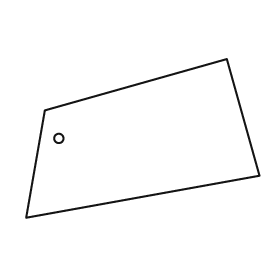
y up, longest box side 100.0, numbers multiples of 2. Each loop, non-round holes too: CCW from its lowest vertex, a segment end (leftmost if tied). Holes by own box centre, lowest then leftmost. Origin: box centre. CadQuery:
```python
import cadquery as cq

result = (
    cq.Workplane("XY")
    .moveTo(-50.0, -34.0)
    .lineTo(50.0, -16.0)
    .lineTo(36.0, 34.0)
    .lineTo(-42.0, 12.0)
    .close()
    .moveTo(-36.0, 0.0)
    .circle(2.0)
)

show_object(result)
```